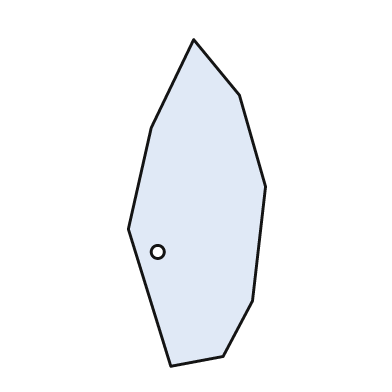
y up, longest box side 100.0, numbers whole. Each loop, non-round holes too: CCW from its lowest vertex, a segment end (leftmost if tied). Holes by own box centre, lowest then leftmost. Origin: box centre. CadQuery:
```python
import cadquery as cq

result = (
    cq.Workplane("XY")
    .moveTo(-8.0, -50.0)
    .lineTo(8.0, -47.0)
    .lineTo(17.0, -30.0)
    .lineTo(21.0, 5.0)
    .lineTo(13.0, 33.0)
    .lineTo(-1.0, 50.0)
    .lineTo(-14.0, 23.0)
    .lineTo(-21.0, -8.0)
    .close()
    .moveTo(-12.0, -15.0)
    .circle(2.0)
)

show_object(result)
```